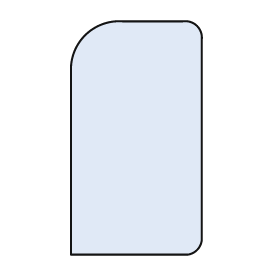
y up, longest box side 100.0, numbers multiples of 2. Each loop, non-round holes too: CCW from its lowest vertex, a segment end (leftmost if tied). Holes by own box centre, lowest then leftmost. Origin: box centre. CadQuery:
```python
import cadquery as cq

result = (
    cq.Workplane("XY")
    .moveTo(-28.0, -50.0)
    .lineTo(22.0, -50.0)
    .threePointArc((26.0, -48.0), (28.0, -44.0))
    .lineTo(28.0, 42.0)
    .threePointArc((26.0, 48.0), (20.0, 50.0))
    .lineTo(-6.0, 50.0)
    .threePointArc((-22.0, 44.0), (-28.0, 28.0))
    .close()
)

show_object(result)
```